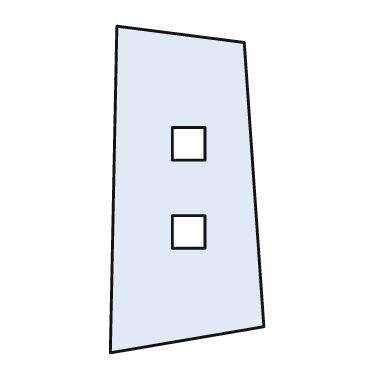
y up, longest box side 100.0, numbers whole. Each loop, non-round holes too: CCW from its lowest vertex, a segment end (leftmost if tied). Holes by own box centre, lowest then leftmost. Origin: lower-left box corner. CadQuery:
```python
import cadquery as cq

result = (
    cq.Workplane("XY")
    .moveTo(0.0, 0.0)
    .lineTo(47.0, 8.0)
    .lineTo(41.0, 95.0)
    .lineTo(2.0, 100.0)
    .close()
    .moveTo(19.0, 32.0)
    .lineTo(29.0, 32.0)
    .lineTo(29.0, 42.0)
    .lineTo(19.0, 42.0)
    .close()
    .moveTo(19.0, 59.0)
    .lineTo(29.0, 59.0)
    .lineTo(29.0, 69.0)
    .lineTo(19.0, 69.0)
    .close()
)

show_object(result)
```